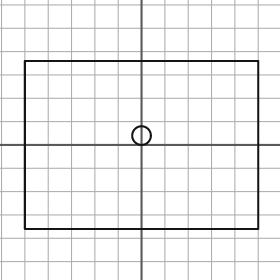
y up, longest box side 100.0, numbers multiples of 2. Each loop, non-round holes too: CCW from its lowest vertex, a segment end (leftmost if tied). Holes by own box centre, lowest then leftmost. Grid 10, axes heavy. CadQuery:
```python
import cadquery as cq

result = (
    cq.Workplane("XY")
    .moveTo(-50.0, -36.0)
    .lineTo(50.0, -36.0)
    .lineTo(50.0, 36.0)
    .lineTo(-50.0, 36.0)
    .close()
    .moveTo(0.0, 4.0)
    .circle(4.0)
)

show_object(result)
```